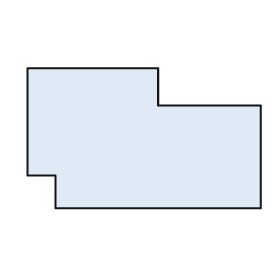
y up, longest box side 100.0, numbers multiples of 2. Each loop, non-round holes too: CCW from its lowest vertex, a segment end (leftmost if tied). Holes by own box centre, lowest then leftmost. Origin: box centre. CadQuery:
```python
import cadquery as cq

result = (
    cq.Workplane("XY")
    .moveTo(-38.0, -30.0)
    .lineTo(50.0, -30.0)
    .lineTo(50.0, 14.0)
    .lineTo(6.0, 14.0)
    .lineTo(6.0, 30.0)
    .lineTo(-50.0, 30.0)
    .lineTo(-50.0, -16.0)
    .lineTo(-38.0, -16.0)
    .close()
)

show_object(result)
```